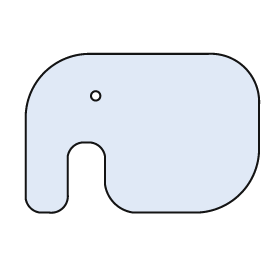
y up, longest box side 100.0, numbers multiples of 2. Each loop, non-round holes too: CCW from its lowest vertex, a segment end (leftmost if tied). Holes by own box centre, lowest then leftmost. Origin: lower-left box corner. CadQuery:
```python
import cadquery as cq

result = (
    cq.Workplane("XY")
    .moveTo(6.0, 0.0)
    .lineTo(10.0, 0.0)
    .threePointArc((16.0, 2.0), (18.0, 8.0))
    .lineTo(18.0, 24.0)
    .threePointArc((20.0, 28.0), (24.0, 30.0))
    .lineTo(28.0, 30.0)
    .threePointArc((32.0, 28.0), (34.0, 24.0))
    .lineTo(34.0, 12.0)
    .threePointArc((38.0, 4.0), (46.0, 0.0))
    .lineTo(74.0, 0.0)
    .threePointArc((92.0, 8.0), (100.0, 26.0))
    .lineTo(100.0, 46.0)
    .threePointArc((94.0, 62.0), (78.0, 68.0))
    .lineTo(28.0, 68.0)
    .threePointArc((8.0, 60.0), (0.0, 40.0))
    .lineTo(0.0, 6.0)
    .threePointArc((2.0, 2.0), (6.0, 0.0))
    .close()
    .moveTo(30.0, 50.0)
    .circle(2.0)
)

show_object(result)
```